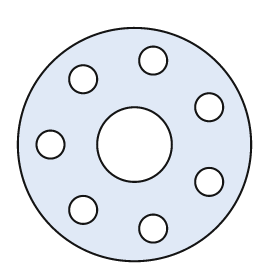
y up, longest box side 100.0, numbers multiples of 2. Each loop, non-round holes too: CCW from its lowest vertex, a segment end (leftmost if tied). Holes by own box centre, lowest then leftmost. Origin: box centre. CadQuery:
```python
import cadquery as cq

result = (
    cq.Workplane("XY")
    .moveTo(0.0, 0.0)
    .circle(50.0)
    .moveTo(8.0, -36.0)
    .circle(6.0)
    .moveTo(-22.0, -28.0)
    .circle(6.0)
    .moveTo(32.0, -16.0)
    .circle(6.0)
    .moveTo(-36.0, 0.0)
    .circle(6.0)
    .moveTo(0.0, 0.0)
    .circle(16.0)
    .moveTo(32.0, 16.0)
    .circle(6.0)
    .moveTo(-22.0, 28.0)
    .circle(6.0)
    .moveTo(8.0, 36.0)
    .circle(6.0)
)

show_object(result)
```